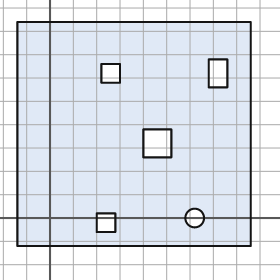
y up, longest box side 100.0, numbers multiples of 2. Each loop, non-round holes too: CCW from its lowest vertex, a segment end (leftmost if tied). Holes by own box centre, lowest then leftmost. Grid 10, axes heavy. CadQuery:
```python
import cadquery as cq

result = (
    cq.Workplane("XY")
    .moveTo(-14.0, -12.0)
    .lineTo(86.0, -12.0)
    .lineTo(86.0, 84.0)
    .lineTo(-14.0, 84.0)
    .close()
    .moveTo(20.0, -6.0)
    .lineTo(28.0, -6.0)
    .lineTo(28.0, 2.0)
    .lineTo(20.0, 2.0)
    .close()
    .moveTo(62.0, 0.0)
    .circle(4.0)
    .moveTo(40.0, 26.0)
    .lineTo(52.0, 26.0)
    .lineTo(52.0, 38.0)
    .lineTo(40.0, 38.0)
    .close()
    .moveTo(22.0, 58.0)
    .lineTo(30.0, 58.0)
    .lineTo(30.0, 66.0)
    .lineTo(22.0, 66.0)
    .close()
    .moveTo(68.0, 56.0)
    .lineTo(76.0, 56.0)
    .lineTo(76.0, 68.0)
    .lineTo(68.0, 68.0)
    .close()
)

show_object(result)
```